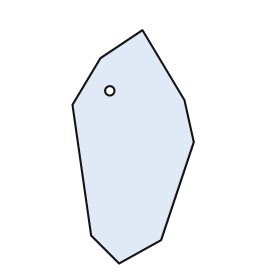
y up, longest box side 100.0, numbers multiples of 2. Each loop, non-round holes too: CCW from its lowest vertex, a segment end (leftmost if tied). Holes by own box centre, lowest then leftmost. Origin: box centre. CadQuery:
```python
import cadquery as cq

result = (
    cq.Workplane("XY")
    .moveTo(-6.0, -50.0)
    .lineTo(12.0, -40.0)
    .lineTo(26.0, 2.0)
    .lineTo(22.0, 20.0)
    .lineTo(4.0, 50.0)
    .lineTo(-14.0, 38.0)
    .lineTo(-26.0, 18.0)
    .lineTo(-18.0, -38.0)
    .close()
    .moveTo(-10.0, 24.0)
    .circle(2.0)
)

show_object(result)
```